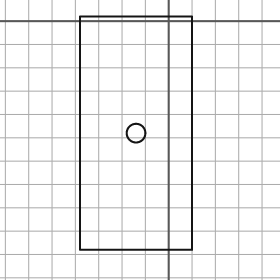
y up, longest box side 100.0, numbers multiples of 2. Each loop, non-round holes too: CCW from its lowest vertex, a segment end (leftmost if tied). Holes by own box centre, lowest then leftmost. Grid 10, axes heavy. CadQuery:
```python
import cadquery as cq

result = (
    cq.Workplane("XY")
    .moveTo(-38.0, -98.0)
    .lineTo(10.0, -98.0)
    .lineTo(10.0, 2.0)
    .lineTo(-38.0, 2.0)
    .close()
    .moveTo(-14.0, -48.0)
    .circle(4.0)
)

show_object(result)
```